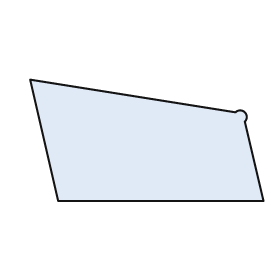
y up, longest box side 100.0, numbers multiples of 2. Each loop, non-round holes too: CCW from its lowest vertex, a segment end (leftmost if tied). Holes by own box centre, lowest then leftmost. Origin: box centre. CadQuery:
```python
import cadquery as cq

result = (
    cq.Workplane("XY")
    .moveTo(-38.0, -26.0)
    .lineTo(50.0, -26.0)
    .lineTo(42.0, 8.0)
    .threePointArc((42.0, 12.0), (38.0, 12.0))
    .lineTo(-50.0, 26.0)
    .close()
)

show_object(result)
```